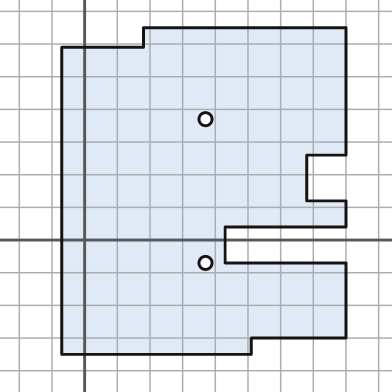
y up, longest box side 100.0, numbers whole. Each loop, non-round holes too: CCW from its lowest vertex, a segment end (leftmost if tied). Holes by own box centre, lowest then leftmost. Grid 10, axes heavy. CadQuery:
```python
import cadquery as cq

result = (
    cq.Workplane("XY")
    .moveTo(-7.0, -35.0)
    .lineTo(51.0, -35.0)
    .lineTo(51.0, -30.0)
    .lineTo(80.0, -30.0)
    .lineTo(80.0, -7.0)
    .lineTo(43.0, -7.0)
    .lineTo(43.0, 4.0)
    .lineTo(80.0, 4.0)
    .lineTo(80.0, 12.0)
    .lineTo(68.0, 12.0)
    .lineTo(68.0, 26.0)
    .lineTo(80.0, 26.0)
    .lineTo(80.0, 65.0)
    .lineTo(18.0, 65.0)
    .lineTo(18.0, 59.0)
    .lineTo(-7.0, 59.0)
    .close()
    .moveTo(37.0, -7.0)
    .circle(2.0)
    .moveTo(37.0, 37.0)
    .circle(2.0)
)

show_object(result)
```